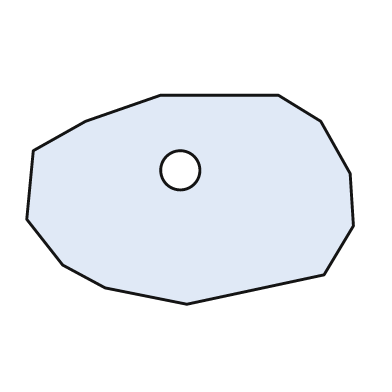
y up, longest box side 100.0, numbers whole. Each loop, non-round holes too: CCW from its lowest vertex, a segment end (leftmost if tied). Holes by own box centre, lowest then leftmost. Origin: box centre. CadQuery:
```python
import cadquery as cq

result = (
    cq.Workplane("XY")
    .moveTo(-1.0, -32.0)
    .lineTo(41.0, -23.0)
    .lineTo(50.0, -8.0)
    .lineTo(49.0, 8.0)
    .lineTo(40.0, 24.0)
    .lineTo(27.0, 32.0)
    .lineTo(-9.0, 32.0)
    .lineTo(-32.0, 24.0)
    .lineTo(-48.0, 15.0)
    .lineTo(-50.0, -6.0)
    .lineTo(-39.0, -20.0)
    .lineTo(-26.0, -27.0)
    .close()
    .moveTo(-3.0, 9.0)
    .circle(6.0)
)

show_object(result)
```